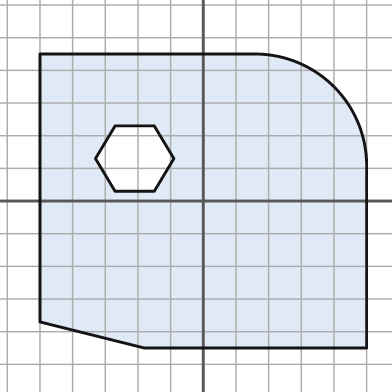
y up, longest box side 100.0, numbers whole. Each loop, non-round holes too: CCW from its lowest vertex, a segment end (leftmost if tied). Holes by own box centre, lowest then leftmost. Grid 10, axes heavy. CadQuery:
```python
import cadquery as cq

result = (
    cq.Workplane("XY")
    .moveTo(-18.0, -45.0)
    .lineTo(50.0, -45.0)
    .lineTo(50.0, 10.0)
    .threePointArc((40.0, 35.0), (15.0, 45.0))
    .lineTo(-50.0, 45.0)
    .lineTo(-50.0, -37.0)
    .close()
    .moveTo(-27.0, 3.0)
    .lineTo(-15.0, 3.0)
    .lineTo(-9.0, 13.0)
    .lineTo(-15.0, 23.0)
    .lineTo(-27.0, 23.0)
    .lineTo(-33.0, 13.0)
    .close()
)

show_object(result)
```